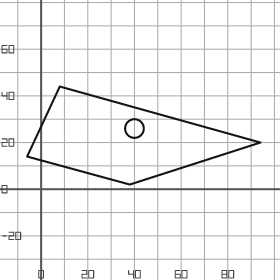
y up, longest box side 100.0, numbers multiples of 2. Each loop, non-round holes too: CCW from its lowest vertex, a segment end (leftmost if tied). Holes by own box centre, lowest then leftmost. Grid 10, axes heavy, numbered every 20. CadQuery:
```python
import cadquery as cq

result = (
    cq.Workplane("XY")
    .moveTo(38.0, 2.0)
    .lineTo(94.0, 20.0)
    .lineTo(8.0, 44.0)
    .lineTo(-6.0, 14.0)
    .close()
    .moveTo(40.0, 26.0)
    .circle(4.0)
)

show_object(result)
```